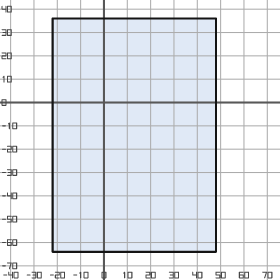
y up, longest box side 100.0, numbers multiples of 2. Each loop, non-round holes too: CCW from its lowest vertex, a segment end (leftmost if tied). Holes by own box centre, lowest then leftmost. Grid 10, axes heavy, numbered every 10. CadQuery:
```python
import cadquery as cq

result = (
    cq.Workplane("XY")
    .moveTo(-22.0, -64.0)
    .lineTo(48.0, -64.0)
    .lineTo(48.0, 36.0)
    .lineTo(-22.0, 36.0)
    .close()
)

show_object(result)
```